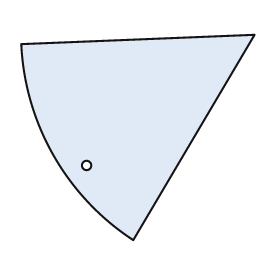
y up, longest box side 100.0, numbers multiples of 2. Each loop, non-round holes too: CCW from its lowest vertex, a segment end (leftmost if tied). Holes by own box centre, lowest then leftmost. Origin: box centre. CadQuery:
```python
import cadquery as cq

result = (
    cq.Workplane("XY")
    .moveTo(-2.0, -44.0)
    .lineTo(50.0, 44.0)
    .lineTo(-50.0, 40.0)
    .threePointArc((-36.0, -8.0), (-2.0, -44.0))
    .close()
    .moveTo(-22.0, -12.0)
    .circle(2.0)
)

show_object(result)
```